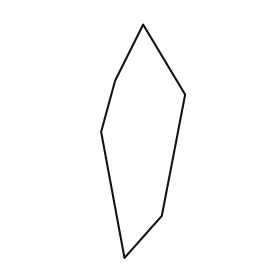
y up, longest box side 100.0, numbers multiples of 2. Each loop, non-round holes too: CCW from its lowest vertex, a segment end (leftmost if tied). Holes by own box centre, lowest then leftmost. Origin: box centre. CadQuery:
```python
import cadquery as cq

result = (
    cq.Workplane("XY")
    .moveTo(-8.0, -50.0)
    .lineTo(8.0, -32.0)
    .lineTo(18.0, 20.0)
    .lineTo(0.0, 50.0)
    .lineTo(-12.0, 26.0)
    .lineTo(-18.0, 4.0)
    .close()
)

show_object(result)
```